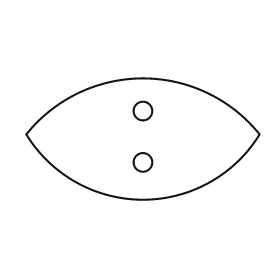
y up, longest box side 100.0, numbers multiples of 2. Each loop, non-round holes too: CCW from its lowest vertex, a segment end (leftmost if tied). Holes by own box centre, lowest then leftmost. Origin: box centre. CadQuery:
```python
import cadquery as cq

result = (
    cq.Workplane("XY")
    .moveTo(-50.0, 2.0)
    .threePointArc((0.0, -26.0), (50.0, 2.0))
    .threePointArc((0.0, 26.0), (-50.0, 2.0))
    .close()
    .moveTo(0.0, -10.0)
    .circle(4.0)
    .moveTo(0.0, 12.0)
    .circle(4.0)
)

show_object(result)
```